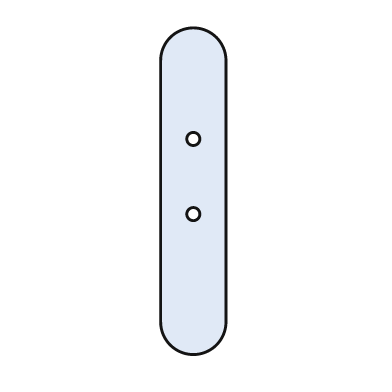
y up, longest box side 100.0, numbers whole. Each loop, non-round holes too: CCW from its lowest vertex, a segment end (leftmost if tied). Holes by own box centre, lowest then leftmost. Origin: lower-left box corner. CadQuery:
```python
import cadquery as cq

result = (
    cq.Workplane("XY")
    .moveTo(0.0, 10.0)
    .threePointArc((10.0, 0.0), (20.0, 10.0))
    .lineTo(20.0, 90.0)
    .threePointArc((10.0, 100.0), (0.0, 90.0))
    .close()
    .moveTo(10.0, 43.0)
    .circle(2.0)
    .moveTo(10.0, 66.0)
    .circle(2.0)
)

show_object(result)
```